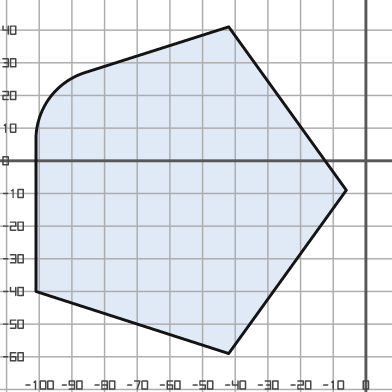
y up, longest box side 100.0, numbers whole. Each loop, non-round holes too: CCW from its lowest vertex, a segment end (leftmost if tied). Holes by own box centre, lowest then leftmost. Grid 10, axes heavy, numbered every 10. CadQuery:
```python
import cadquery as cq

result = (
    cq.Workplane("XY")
    .moveTo(-42.0, -59.0)
    .lineTo(-6.0, -9.0)
    .lineTo(-42.0, 41.0)
    .lineTo(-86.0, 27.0)
    .threePointArc((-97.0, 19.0), (-101.0, 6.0))
    .lineTo(-101.0, -40.0)
    .close()
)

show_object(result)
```